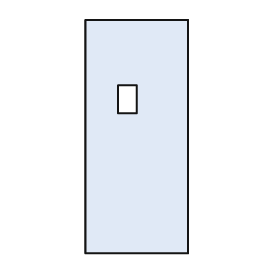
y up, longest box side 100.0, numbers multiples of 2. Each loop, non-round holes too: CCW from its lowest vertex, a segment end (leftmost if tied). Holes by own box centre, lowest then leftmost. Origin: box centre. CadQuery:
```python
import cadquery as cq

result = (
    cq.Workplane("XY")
    .moveTo(-22.0, -50.0)
    .lineTo(22.0, -50.0)
    .lineTo(22.0, 50.0)
    .lineTo(-22.0, 50.0)
    .close()
    .moveTo(-8.0, 10.0)
    .lineTo(0.0, 10.0)
    .lineTo(0.0, 22.0)
    .lineTo(-8.0, 22.0)
    .close()
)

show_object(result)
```